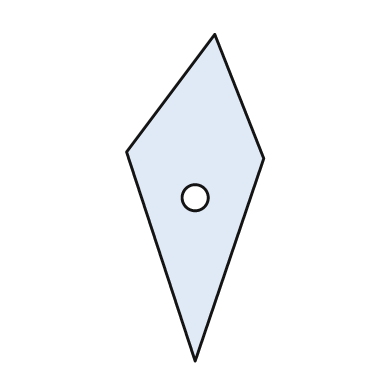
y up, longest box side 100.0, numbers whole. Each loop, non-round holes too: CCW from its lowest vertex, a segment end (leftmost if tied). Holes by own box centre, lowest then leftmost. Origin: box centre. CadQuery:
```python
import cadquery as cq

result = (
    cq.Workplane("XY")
    .moveTo(0.0, -50.0)
    .lineTo(21.0, 12.0)
    .lineTo(6.0, 50.0)
    .lineTo(-21.0, 14.0)
    .close()
    .moveTo(0.0, 0.0)
    .circle(4.0)
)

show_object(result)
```